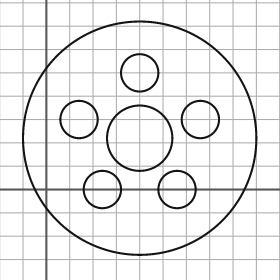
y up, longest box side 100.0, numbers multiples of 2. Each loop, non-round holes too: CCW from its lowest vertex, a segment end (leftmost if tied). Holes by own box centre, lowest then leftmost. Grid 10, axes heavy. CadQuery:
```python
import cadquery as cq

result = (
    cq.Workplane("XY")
    .moveTo(40.0, 22.0)
    .circle(50.0)
    .moveTo(24.0, 0.0)
    .circle(8.0)
    .moveTo(56.0, 0.0)
    .circle(8.0)
    .moveTo(40.0, 22.0)
    .circle(14.0)
    .moveTo(14.0, 30.0)
    .circle(8.0)
    .moveTo(66.0, 30.0)
    .circle(8.0)
    .moveTo(40.0, 50.0)
    .circle(8.0)
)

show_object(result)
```